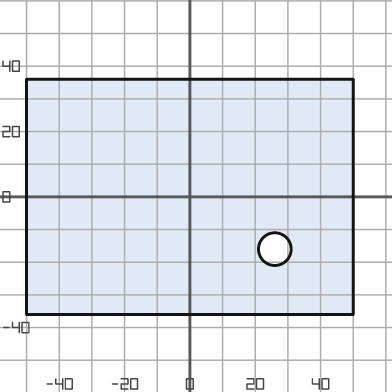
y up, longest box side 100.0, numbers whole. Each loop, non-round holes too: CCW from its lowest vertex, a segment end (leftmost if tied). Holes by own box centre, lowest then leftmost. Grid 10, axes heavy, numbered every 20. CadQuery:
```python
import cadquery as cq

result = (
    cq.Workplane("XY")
    .moveTo(-50.0, -36.0)
    .lineTo(50.0, -36.0)
    .lineTo(50.0, 36.0)
    .lineTo(-50.0, 36.0)
    .close()
    .moveTo(26.0, -16.0)
    .circle(5.0)
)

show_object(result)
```